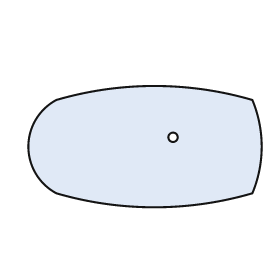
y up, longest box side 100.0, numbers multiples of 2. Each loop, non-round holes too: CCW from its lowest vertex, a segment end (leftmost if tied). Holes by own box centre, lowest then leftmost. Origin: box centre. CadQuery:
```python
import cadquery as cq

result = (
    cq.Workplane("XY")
    .moveTo(-38.0, -20.0)
    .threePointArc((4.0, -26.0), (46.0, -20.0))
    .threePointArc((50.0, 0.0), (46.0, 20.0))
    .threePointArc((4.0, 26.0), (-38.0, 20.0))
    .threePointArc((-50.0, 0.0), (-38.0, -20.0))
    .close()
    .moveTo(12.0, 4.0)
    .circle(2.0)
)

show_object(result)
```